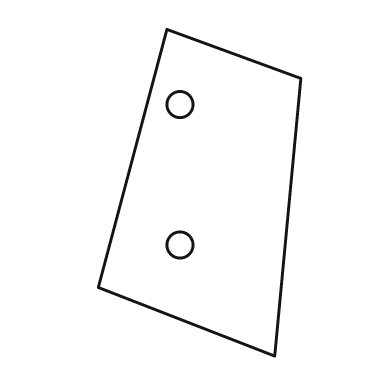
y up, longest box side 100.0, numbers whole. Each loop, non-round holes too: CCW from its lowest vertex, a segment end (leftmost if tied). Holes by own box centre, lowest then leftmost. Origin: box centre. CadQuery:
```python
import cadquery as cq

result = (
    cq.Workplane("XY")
    .moveTo(23.0, -50.0)
    .lineTo(31.0, 35.0)
    .lineTo(-10.0, 50.0)
    .lineTo(-31.0, -29.0)
    .close()
    .moveTo(-6.0, -16.0)
    .circle(4.0)
    .moveTo(-6.0, 27.0)
    .circle(4.0)
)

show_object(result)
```